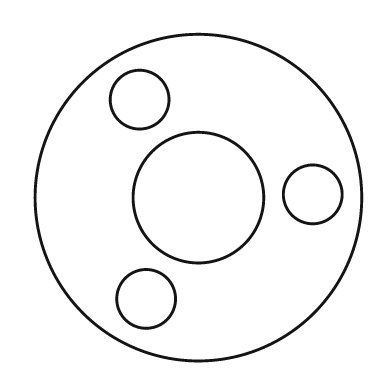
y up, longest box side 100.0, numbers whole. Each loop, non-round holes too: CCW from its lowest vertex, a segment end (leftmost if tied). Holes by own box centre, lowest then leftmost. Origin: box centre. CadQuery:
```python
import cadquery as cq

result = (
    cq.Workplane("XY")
    .moveTo(0.0, 0.0)
    .circle(50.0)
    .moveTo(-16.0, -31.0)
    .circle(9.0)
    .moveTo(0.0, 0.0)
    .circle(20.0)
    .moveTo(35.0, 1.0)
    .circle(9.0)
    .moveTo(-18.0, 30.0)
    .circle(9.0)
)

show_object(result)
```